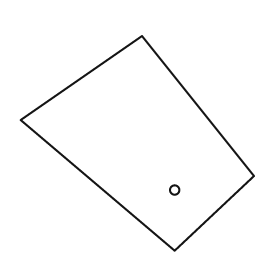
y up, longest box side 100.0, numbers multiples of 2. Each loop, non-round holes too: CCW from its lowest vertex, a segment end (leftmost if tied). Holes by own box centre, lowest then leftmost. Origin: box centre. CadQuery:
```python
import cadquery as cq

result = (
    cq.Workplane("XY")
    .moveTo(16.0, -46.0)
    .lineTo(50.0, -14.0)
    .lineTo(2.0, 46.0)
    .lineTo(-50.0, 10.0)
    .close()
    .moveTo(16.0, -20.0)
    .circle(2.0)
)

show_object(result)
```